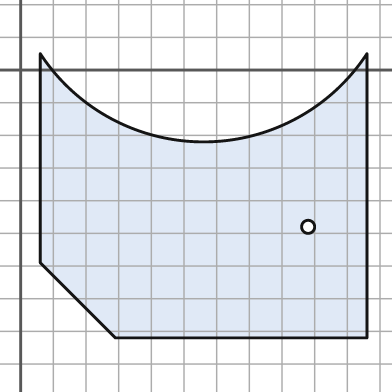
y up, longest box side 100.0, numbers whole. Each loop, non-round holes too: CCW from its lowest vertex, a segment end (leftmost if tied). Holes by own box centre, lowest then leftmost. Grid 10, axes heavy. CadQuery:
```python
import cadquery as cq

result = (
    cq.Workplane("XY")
    .moveTo(29.0, -82.0)
    .lineTo(106.0, -82.0)
    .lineTo(106.0, 5.0)
    .threePointArc((56.0, -22.0), (6.0, 5.0))
    .lineTo(6.0, -59.0)
    .close()
    .moveTo(88.0, -48.0)
    .circle(2.0)
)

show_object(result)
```